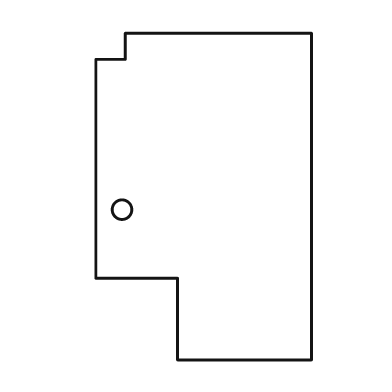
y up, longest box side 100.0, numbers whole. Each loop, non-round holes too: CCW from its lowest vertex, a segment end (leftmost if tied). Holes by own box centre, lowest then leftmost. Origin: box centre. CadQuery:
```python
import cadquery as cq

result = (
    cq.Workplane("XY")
    .moveTo(-8.0, -50.0)
    .lineTo(33.0, -50.0)
    .lineTo(33.0, 50.0)
    .lineTo(-24.0, 50.0)
    .lineTo(-24.0, 42.0)
    .lineTo(-33.0, 42.0)
    .lineTo(-33.0, -25.0)
    .lineTo(-8.0, -25.0)
    .close()
    .moveTo(-25.0, -4.0)
    .circle(3.0)
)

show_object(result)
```